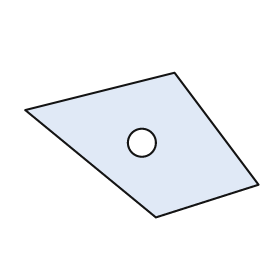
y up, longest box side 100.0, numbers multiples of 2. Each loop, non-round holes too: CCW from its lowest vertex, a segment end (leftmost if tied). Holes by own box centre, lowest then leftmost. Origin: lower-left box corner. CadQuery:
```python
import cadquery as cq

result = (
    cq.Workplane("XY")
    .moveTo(56.0, 0.0)
    .lineTo(100.0, 14.0)
    .lineTo(64.0, 62.0)
    .lineTo(0.0, 46.0)
    .close()
    .moveTo(50.0, 32.0)
    .circle(6.0)
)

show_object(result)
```